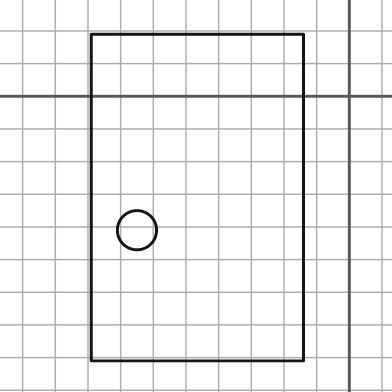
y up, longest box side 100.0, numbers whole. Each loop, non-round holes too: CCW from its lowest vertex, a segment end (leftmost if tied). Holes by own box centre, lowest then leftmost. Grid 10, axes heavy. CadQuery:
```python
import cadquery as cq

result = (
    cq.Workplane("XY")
    .moveTo(-79.0, -81.0)
    .lineTo(-14.0, -81.0)
    .lineTo(-14.0, 19.0)
    .lineTo(-79.0, 19.0)
    .close()
    .moveTo(-65.0, -41.0)
    .circle(6.0)
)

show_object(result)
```